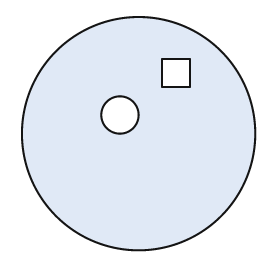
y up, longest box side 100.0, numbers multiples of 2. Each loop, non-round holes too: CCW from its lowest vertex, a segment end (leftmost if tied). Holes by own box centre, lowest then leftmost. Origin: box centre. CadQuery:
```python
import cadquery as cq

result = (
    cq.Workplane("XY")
    .moveTo(0.0, 0.0)
    .circle(50.0)
    .moveTo(-8.0, 8.0)
    .circle(8.0)
    .moveTo(10.0, 20.0)
    .lineTo(22.0, 20.0)
    .lineTo(22.0, 32.0)
    .lineTo(10.0, 32.0)
    .close()
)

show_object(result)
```